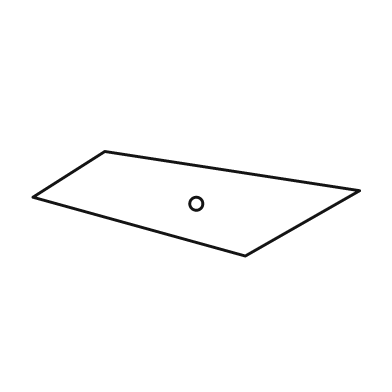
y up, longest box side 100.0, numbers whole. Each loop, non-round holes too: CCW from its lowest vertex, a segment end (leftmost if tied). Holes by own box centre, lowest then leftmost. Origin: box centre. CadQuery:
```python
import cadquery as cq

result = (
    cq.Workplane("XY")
    .moveTo(15.0, -16.0)
    .lineTo(50.0, 4.0)
    .lineTo(-28.0, 16.0)
    .lineTo(-50.0, 2.0)
    .close()
    .moveTo(0.0, 0.0)
    .circle(2.0)
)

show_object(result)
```